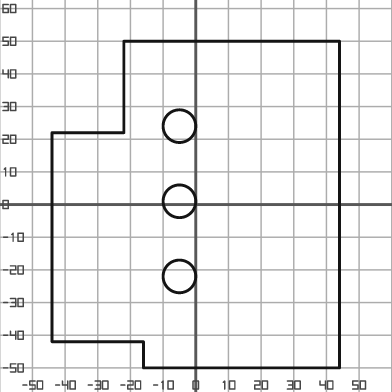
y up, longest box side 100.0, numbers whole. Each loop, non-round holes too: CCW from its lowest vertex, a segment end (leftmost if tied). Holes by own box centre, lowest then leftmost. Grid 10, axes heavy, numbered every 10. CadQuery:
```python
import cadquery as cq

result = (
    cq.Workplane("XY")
    .moveTo(-16.0, -50.0)
    .lineTo(44.0, -50.0)
    .lineTo(44.0, 50.0)
    .lineTo(-22.0, 50.0)
    .lineTo(-22.0, 22.0)
    .lineTo(-44.0, 22.0)
    .lineTo(-44.0, -42.0)
    .lineTo(-16.0, -42.0)
    .close()
    .moveTo(-5.0, -22.0)
    .circle(5.0)
    .moveTo(-5.0, 1.0)
    .circle(5.0)
    .moveTo(-5.0, 24.0)
    .circle(5.0)
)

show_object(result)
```